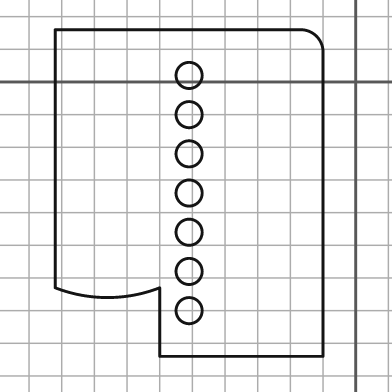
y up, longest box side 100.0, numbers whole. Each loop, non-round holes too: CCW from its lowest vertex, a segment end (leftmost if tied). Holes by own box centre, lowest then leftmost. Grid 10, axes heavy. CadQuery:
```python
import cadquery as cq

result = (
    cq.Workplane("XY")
    .moveTo(-60.0, -84.0)
    .lineTo(-10.0, -84.0)
    .lineTo(-10.0, 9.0)
    .threePointArc((-12.0, 14.0), (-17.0, 16.0))
    .lineTo(-92.0, 16.0)
    .lineTo(-92.0, -63.0)
    .threePointArc((-76.0, -66.0), (-60.0, -63.0))
    .close()
    .moveTo(-51.0, -70.0)
    .circle(4.0)
    .moveTo(-51.0, -58.0)
    .circle(4.0)
    .moveTo(-51.0, -46.0)
    .circle(4.0)
    .moveTo(-51.0, -34.0)
    .circle(4.0)
    .moveTo(-51.0, -22.0)
    .circle(4.0)
    .moveTo(-51.0, -10.0)
    .circle(4.0)
    .moveTo(-51.0, 2.0)
    .circle(4.0)
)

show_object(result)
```